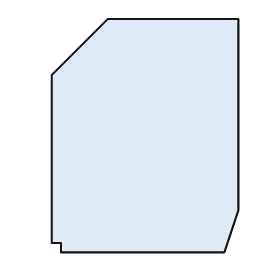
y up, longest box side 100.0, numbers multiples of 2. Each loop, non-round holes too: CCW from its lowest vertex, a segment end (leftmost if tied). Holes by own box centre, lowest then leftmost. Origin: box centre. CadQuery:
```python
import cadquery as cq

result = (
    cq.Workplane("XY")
    .moveTo(-36.0, -50.0)
    .lineTo(34.0, -50.0)
    .lineTo(40.0, -32.0)
    .lineTo(40.0, 50.0)
    .lineTo(-16.0, 50.0)
    .lineTo(-40.0, 26.0)
    .lineTo(-40.0, -46.0)
    .lineTo(-36.0, -46.0)
    .close()
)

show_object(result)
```